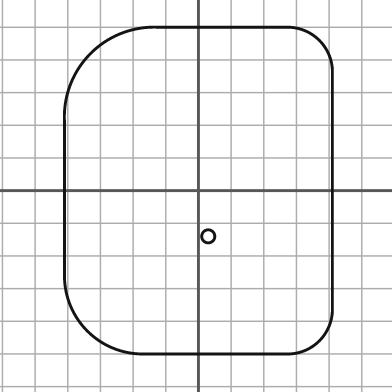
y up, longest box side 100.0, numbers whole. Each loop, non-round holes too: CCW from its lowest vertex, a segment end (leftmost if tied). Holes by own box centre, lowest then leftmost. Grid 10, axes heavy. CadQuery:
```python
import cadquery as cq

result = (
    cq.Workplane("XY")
    .moveTo(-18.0, -50.0)
    .lineTo(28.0, -50.0)
    .threePointArc((37.0, -46.0), (41.0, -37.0))
    .lineTo(41.0, 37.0)
    .threePointArc((37.0, 46.0), (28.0, 50.0))
    .lineTo(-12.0, 50.0)
    .threePointArc((-33.0, 42.0), (-41.0, 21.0))
    .lineTo(-41.0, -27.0)
    .threePointArc((-34.0, -43.0), (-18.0, -50.0))
    .close()
    .moveTo(3.0, -14.0)
    .circle(2.0)
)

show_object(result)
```